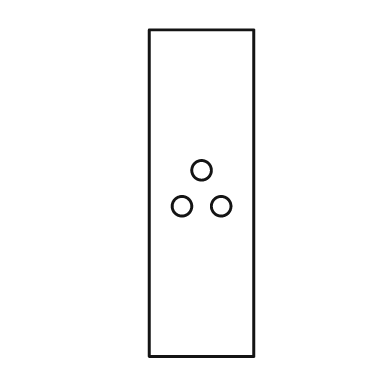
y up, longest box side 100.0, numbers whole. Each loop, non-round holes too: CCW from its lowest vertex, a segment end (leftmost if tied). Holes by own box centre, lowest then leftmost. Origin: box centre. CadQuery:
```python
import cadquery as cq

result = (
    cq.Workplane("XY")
    .moveTo(-16.0, -50.0)
    .lineTo(16.0, -50.0)
    .lineTo(16.0, 50.0)
    .lineTo(-16.0, 50.0)
    .close()
    .moveTo(-6.0, -4.0)
    .circle(3.0)
    .moveTo(6.0, -4.0)
    .circle(3.0)
    .moveTo(0.0, 7.0)
    .circle(3.0)
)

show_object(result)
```